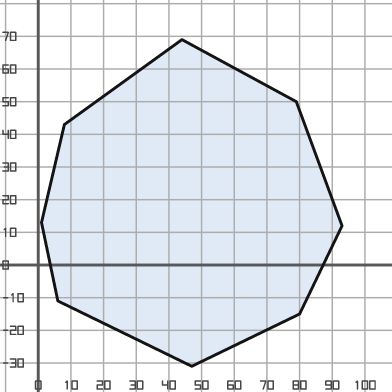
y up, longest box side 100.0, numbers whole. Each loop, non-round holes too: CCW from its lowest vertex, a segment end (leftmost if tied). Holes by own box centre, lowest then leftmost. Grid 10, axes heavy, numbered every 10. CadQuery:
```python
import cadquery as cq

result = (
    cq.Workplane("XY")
    .moveTo(47.0, -31.0)
    .lineTo(80.0, -15.0)
    .lineTo(93.0, 12.0)
    .lineTo(79.0, 50.0)
    .lineTo(44.0, 69.0)
    .lineTo(8.0, 43.0)
    .lineTo(1.0, 13.0)
    .lineTo(6.0, -11.0)
    .close()
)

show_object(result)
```